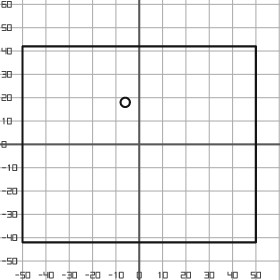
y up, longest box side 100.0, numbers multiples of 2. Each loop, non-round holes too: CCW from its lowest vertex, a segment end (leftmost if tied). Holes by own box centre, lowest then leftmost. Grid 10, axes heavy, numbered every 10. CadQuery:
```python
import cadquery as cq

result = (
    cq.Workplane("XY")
    .moveTo(-50.0, -42.0)
    .lineTo(50.0, -42.0)
    .lineTo(50.0, 42.0)
    .lineTo(-50.0, 42.0)
    .close()
    .moveTo(-6.0, 18.0)
    .circle(2.0)
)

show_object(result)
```